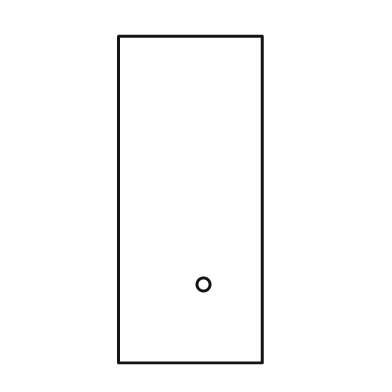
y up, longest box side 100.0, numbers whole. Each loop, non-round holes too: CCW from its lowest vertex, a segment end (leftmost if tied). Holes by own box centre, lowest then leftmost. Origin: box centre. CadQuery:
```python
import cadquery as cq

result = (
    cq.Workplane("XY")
    .moveTo(-22.0, -50.0)
    .lineTo(22.0, -50.0)
    .lineTo(22.0, 50.0)
    .lineTo(-22.0, 50.0)
    .close()
    .moveTo(4.0, -26.0)
    .circle(2.0)
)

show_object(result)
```